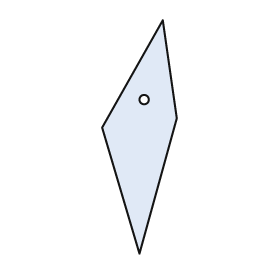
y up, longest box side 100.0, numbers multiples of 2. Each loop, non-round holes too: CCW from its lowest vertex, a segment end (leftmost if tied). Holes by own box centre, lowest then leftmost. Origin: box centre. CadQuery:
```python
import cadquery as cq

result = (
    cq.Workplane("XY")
    .moveTo(0.0, -50.0)
    .lineTo(16.0, 8.0)
    .lineTo(10.0, 50.0)
    .lineTo(-16.0, 4.0)
    .close()
    .moveTo(2.0, 16.0)
    .circle(2.0)
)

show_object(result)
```